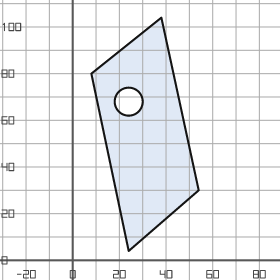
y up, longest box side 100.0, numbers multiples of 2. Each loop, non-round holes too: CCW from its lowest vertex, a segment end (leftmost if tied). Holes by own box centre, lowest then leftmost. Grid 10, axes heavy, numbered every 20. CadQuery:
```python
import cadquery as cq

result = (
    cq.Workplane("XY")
    .moveTo(24.0, 4.0)
    .lineTo(54.0, 30.0)
    .lineTo(38.0, 104.0)
    .lineTo(8.0, 80.0)
    .close()
    .moveTo(24.0, 68.0)
    .circle(6.0)
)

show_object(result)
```